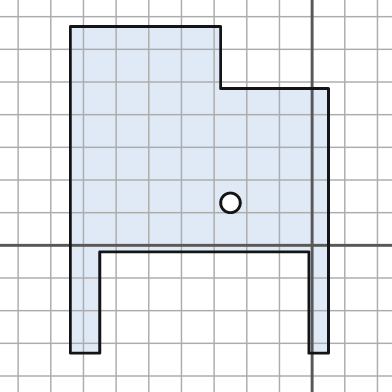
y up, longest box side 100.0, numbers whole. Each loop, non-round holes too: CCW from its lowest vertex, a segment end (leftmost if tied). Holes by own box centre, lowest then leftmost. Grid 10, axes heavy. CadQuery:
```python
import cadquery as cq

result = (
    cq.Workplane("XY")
    .moveTo(-74.0, -33.0)
    .lineTo(-65.0, -33.0)
    .lineTo(-65.0, -2.0)
    .lineTo(-1.0, -2.0)
    .lineTo(-1.0, -33.0)
    .lineTo(5.0, -33.0)
    .lineTo(5.0, 48.0)
    .lineTo(-28.0, 48.0)
    .lineTo(-28.0, 67.0)
    .lineTo(-74.0, 67.0)
    .close()
    .moveTo(-25.0, 13.0)
    .circle(3.0)
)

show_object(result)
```